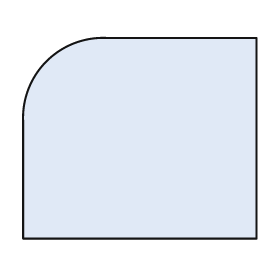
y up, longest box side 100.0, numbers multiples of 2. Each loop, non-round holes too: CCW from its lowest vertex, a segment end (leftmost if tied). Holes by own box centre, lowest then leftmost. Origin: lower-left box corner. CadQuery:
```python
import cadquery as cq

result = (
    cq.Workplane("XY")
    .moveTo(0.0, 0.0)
    .lineTo(100.0, 0.0)
    .lineTo(100.0, 86.0)
    .lineTo(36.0, 86.0)
    .threePointArc((10.0, 76.0), (0.0, 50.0))
    .close()
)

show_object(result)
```